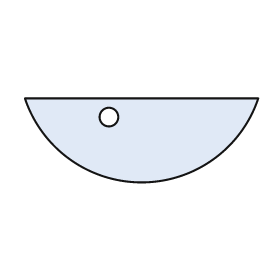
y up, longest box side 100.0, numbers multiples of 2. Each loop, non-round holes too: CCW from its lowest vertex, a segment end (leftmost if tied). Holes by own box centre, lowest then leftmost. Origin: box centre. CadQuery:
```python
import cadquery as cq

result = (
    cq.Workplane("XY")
    .moveTo(-50.0, 18.0)
    .threePointArc((0.0, -18.0), (50.0, 18.0))
    .close()
    .moveTo(-14.0, 10.0)
    .circle(4.0)
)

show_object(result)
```